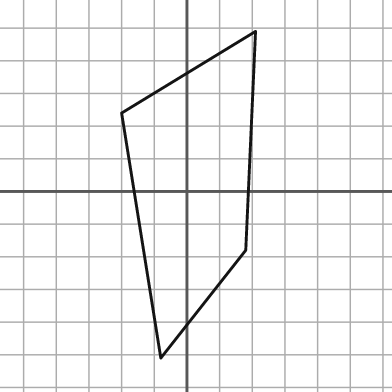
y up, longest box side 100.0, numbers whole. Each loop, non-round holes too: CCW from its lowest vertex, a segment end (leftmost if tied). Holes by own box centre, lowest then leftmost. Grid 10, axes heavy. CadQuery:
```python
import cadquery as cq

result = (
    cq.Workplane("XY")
    .moveTo(-8.0, -51.0)
    .lineTo(18.0, -18.0)
    .lineTo(21.0, 49.0)
    .lineTo(-20.0, 24.0)
    .close()
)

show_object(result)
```